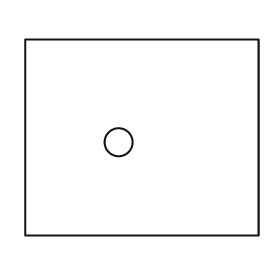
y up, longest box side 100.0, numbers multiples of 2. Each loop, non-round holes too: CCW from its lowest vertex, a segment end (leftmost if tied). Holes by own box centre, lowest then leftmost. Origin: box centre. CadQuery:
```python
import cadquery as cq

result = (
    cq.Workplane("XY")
    .moveTo(-50.0, -42.0)
    .lineTo(50.0, -42.0)
    .lineTo(50.0, 42.0)
    .lineTo(-50.0, 42.0)
    .close()
    .moveTo(-10.0, -2.0)
    .circle(6.0)
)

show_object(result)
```